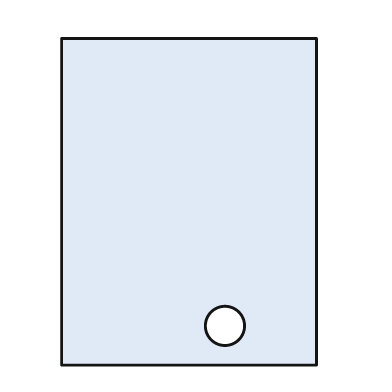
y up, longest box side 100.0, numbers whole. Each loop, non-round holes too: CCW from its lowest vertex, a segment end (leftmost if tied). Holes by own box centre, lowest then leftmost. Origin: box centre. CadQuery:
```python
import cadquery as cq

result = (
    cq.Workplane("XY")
    .moveTo(-39.0, -50.0)
    .lineTo(39.0, -50.0)
    .lineTo(39.0, 50.0)
    .lineTo(-39.0, 50.0)
    .close()
    .moveTo(11.0, -38.0)
    .circle(6.0)
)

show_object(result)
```